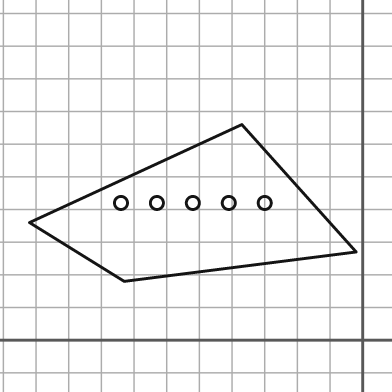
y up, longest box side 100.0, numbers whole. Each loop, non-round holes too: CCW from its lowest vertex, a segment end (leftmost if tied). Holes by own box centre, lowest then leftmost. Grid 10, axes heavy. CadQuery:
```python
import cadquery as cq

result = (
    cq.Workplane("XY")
    .moveTo(-73.0, 18.0)
    .lineTo(-2.0, 27.0)
    .lineTo(-37.0, 66.0)
    .lineTo(-102.0, 36.0)
    .close()
    .moveTo(-74.0, 42.0)
    .circle(2.0)
    .moveTo(-63.0, 42.0)
    .circle(2.0)
    .moveTo(-52.0, 42.0)
    .circle(2.0)
    .moveTo(-41.0, 42.0)
    .circle(2.0)
    .moveTo(-30.0, 42.0)
    .circle(2.0)
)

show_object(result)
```